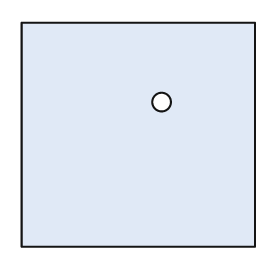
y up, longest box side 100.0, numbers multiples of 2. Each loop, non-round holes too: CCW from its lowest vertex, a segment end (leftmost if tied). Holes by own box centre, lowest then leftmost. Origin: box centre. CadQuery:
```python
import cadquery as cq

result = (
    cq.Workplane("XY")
    .moveTo(-50.0, -48.0)
    .lineTo(50.0, -48.0)
    .lineTo(50.0, 48.0)
    .lineTo(-50.0, 48.0)
    .close()
    .moveTo(10.0, 14.0)
    .circle(4.0)
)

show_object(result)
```